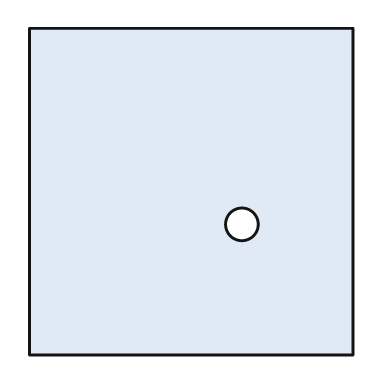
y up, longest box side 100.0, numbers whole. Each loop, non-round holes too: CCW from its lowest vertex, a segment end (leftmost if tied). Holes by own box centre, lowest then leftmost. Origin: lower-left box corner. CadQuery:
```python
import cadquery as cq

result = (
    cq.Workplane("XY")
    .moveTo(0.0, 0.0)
    .lineTo(99.0, 0.0)
    .lineTo(99.0, 100.0)
    .lineTo(0.0, 100.0)
    .close()
    .moveTo(65.0, 40.0)
    .circle(5.0)
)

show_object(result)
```